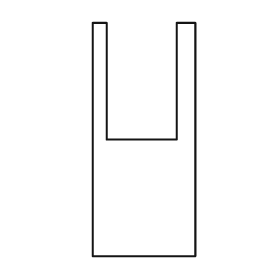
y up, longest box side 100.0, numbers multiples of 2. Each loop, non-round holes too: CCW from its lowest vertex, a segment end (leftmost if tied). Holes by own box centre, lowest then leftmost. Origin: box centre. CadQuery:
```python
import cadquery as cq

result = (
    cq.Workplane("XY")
    .moveTo(-22.0, -50.0)
    .lineTo(22.0, -50.0)
    .lineTo(22.0, 50.0)
    .lineTo(14.0, 50.0)
    .lineTo(14.0, 0.0)
    .lineTo(-16.0, 0.0)
    .lineTo(-16.0, 50.0)
    .lineTo(-22.0, 50.0)
    .close()
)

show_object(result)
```